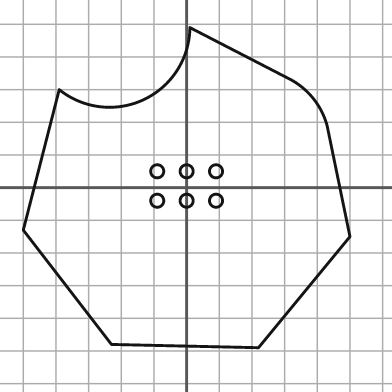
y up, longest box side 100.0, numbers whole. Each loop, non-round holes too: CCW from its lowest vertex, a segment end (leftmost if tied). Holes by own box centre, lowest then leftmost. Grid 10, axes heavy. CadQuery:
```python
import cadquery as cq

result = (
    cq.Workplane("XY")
    .moveTo(22.0, -49.0)
    .lineTo(50.0, -15.0)
    .lineTo(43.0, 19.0)
    .threePointArc((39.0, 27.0), (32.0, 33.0))
    .lineTo(1.0, 49.0)
    .threePointArc((-13.0, 27.0), (-39.0, 30.0))
    .lineTo(-50.0, -13.0)
    .lineTo(-23.0, -48.0)
    .close()
    .moveTo(-9.0, -4.0)
    .circle(2.0)
    .moveTo(0.0, -4.0)
    .circle(2.0)
    .moveTo(9.0, -4.0)
    .circle(2.0)
    .moveTo(-9.0, 5.0)
    .circle(2.0)
    .moveTo(0.0, 5.0)
    .circle(2.0)
    .moveTo(9.0, 5.0)
    .circle(2.0)
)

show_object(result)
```